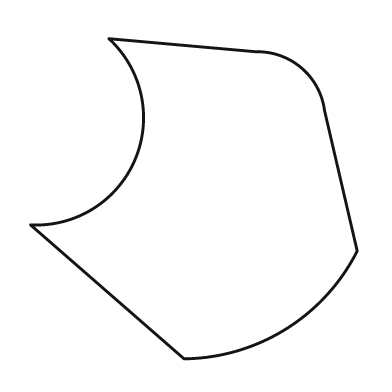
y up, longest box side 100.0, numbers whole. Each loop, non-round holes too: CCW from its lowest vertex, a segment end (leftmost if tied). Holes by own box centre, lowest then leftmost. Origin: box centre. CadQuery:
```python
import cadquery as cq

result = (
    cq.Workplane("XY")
    .moveTo(-3.0, -49.0)
    .threePointArc((28.0, -40.0), (50.0, -16.0))
    .lineTo(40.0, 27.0)
    .threePointArc((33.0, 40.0), (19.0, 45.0))
    .lineTo(-26.0, 49.0)
    .threePointArc((-18.0, 12.0), (-50.0, -8.0))
    .close()
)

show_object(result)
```